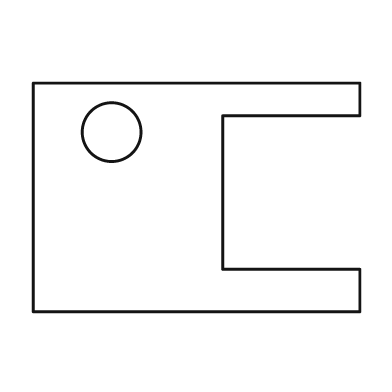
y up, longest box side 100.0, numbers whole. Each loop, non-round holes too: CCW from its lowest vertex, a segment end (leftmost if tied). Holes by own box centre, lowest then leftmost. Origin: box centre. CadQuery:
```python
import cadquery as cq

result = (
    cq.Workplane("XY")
    .moveTo(-50.0, -35.0)
    .lineTo(50.0, -35.0)
    .lineTo(50.0, -22.0)
    .lineTo(8.0, -22.0)
    .lineTo(8.0, 25.0)
    .lineTo(50.0, 25.0)
    .lineTo(50.0, 35.0)
    .lineTo(-50.0, 35.0)
    .close()
    .moveTo(-26.0, 20.0)
    .circle(9.0)
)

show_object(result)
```